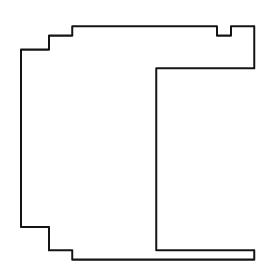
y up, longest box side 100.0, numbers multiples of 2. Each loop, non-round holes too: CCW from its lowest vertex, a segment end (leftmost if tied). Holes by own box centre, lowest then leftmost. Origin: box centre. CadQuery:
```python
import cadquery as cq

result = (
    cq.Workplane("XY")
    .moveTo(-28.0, -50.0)
    .lineTo(50.0, -50.0)
    .lineTo(50.0, -46.0)
    .lineTo(8.0, -46.0)
    .lineTo(8.0, 32.0)
    .lineTo(50.0, 32.0)
    .lineTo(50.0, 50.0)
    .lineTo(40.0, 50.0)
    .lineTo(40.0, 46.0)
    .lineTo(34.0, 46.0)
    .lineTo(34.0, 50.0)
    .lineTo(-28.0, 50.0)
    .lineTo(-28.0, 46.0)
    .lineTo(-38.0, 46.0)
    .lineTo(-38.0, 40.0)
    .lineTo(-50.0, 40.0)
    .lineTo(-50.0, -36.0)
    .lineTo(-38.0, -36.0)
    .lineTo(-38.0, -46.0)
    .lineTo(-28.0, -46.0)
    .close()
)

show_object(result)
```